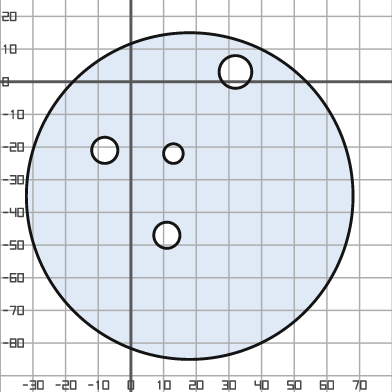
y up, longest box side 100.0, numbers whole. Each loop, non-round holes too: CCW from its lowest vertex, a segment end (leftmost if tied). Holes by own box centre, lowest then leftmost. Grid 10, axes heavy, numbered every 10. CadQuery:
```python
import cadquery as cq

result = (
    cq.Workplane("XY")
    .moveTo(18.0, -35.0)
    .circle(50.0)
    .moveTo(11.0, -47.0)
    .circle(4.0)
    .moveTo(13.0, -22.0)
    .circle(3.0)
    .moveTo(-8.0, -21.0)
    .circle(4.0)
    .moveTo(32.0, 3.0)
    .circle(5.0)
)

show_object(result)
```